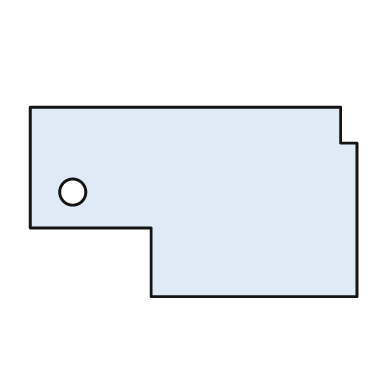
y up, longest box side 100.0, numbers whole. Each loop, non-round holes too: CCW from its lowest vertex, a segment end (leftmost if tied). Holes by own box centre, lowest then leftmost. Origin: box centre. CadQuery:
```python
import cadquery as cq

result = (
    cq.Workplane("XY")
    .moveTo(-13.0, -29.0)
    .lineTo(50.0, -29.0)
    .lineTo(50.0, 18.0)
    .lineTo(45.0, 18.0)
    .lineTo(45.0, 29.0)
    .lineTo(-50.0, 29.0)
    .lineTo(-50.0, -8.0)
    .lineTo(-13.0, -8.0)
    .close()
    .moveTo(-37.0, 3.0)
    .circle(4.0)
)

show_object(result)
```